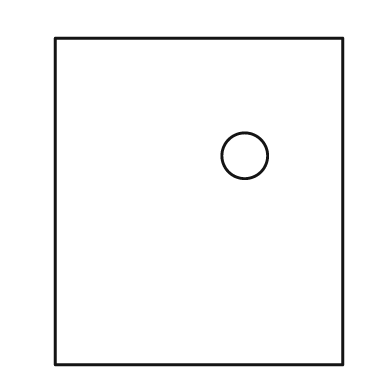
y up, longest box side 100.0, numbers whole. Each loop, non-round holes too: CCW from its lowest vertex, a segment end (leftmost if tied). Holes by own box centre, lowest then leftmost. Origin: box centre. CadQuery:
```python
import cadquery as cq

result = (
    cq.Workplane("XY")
    .moveTo(-44.0, -50.0)
    .lineTo(44.0, -50.0)
    .lineTo(44.0, 50.0)
    .lineTo(-44.0, 50.0)
    .close()
    .moveTo(14.0, 14.0)
    .circle(7.0)
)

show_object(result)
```